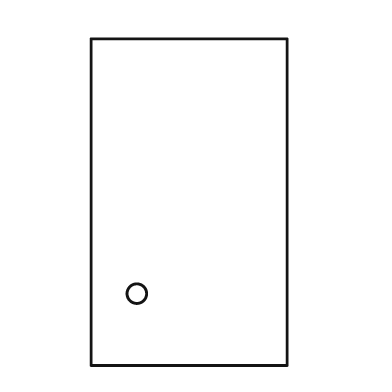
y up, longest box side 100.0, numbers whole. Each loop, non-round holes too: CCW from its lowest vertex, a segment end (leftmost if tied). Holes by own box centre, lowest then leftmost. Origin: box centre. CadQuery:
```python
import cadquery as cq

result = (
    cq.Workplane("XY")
    .moveTo(-30.0, -50.0)
    .lineTo(30.0, -50.0)
    .lineTo(30.0, 50.0)
    .lineTo(-30.0, 50.0)
    .close()
    .moveTo(-16.0, -28.0)
    .circle(3.0)
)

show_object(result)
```